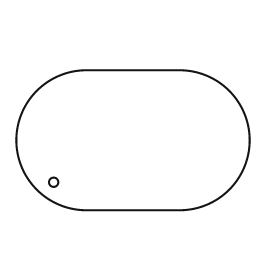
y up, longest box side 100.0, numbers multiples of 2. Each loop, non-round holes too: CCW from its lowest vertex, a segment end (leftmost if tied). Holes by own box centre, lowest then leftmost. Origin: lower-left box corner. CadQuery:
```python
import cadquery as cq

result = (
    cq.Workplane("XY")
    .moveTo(30.0, 0.0)
    .lineTo(70.0, 0.0)
    .threePointArc((100.0, 30.0), (70.0, 60.0))
    .lineTo(30.0, 60.0)
    .threePointArc((0.0, 30.0), (30.0, 0.0))
    .close()
    .moveTo(16.0, 12.0)
    .circle(2.0)
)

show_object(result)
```